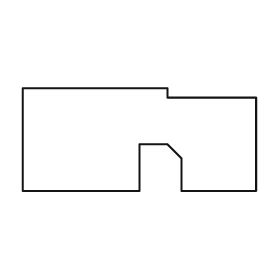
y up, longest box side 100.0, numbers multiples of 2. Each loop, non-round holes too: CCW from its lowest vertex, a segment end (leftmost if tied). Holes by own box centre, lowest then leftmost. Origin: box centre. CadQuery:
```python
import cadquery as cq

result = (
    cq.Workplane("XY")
    .moveTo(-50.0, -22.0)
    .lineTo(0.0, -22.0)
    .lineTo(0.0, -2.0)
    .lineTo(12.0, -2.0)
    .lineTo(18.0, -8.0)
    .lineTo(18.0, -22.0)
    .lineTo(50.0, -22.0)
    .lineTo(50.0, 18.0)
    .lineTo(12.0, 18.0)
    .lineTo(12.0, 22.0)
    .lineTo(-50.0, 22.0)
    .close()
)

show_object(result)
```